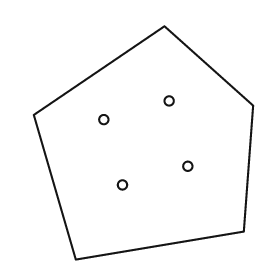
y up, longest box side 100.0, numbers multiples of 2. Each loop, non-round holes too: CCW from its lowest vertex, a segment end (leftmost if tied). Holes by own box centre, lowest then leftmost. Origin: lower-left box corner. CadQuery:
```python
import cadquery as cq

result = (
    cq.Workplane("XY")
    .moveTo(18.0, 0.0)
    .lineTo(90.0, 12.0)
    .lineTo(94.0, 66.0)
    .lineTo(56.0, 100.0)
    .lineTo(0.0, 62.0)
    .close()
    .moveTo(38.0, 32.0)
    .circle(2.0)
    .moveTo(66.0, 40.0)
    .circle(2.0)
    .moveTo(30.0, 60.0)
    .circle(2.0)
    .moveTo(58.0, 68.0)
    .circle(2.0)
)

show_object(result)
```